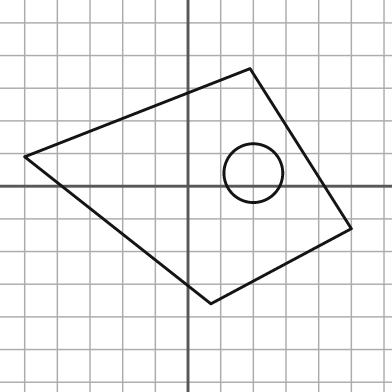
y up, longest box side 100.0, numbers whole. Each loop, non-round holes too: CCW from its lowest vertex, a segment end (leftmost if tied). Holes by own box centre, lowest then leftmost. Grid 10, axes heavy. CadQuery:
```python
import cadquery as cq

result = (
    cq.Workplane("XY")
    .moveTo(7.0, -36.0)
    .lineTo(50.0, -13.0)
    .lineTo(19.0, 36.0)
    .lineTo(-50.0, 9.0)
    .close()
    .moveTo(20.0, 4.0)
    .circle(9.0)
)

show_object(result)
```